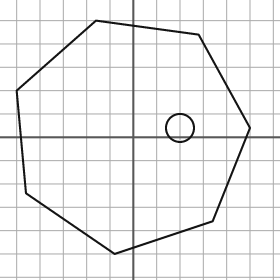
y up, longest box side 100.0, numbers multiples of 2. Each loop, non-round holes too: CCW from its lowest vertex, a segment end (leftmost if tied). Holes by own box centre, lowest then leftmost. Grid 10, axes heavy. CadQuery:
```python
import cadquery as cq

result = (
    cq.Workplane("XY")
    .moveTo(-8.0, -50.0)
    .lineTo(34.0, -36.0)
    .lineTo(50.0, 4.0)
    .lineTo(28.0, 44.0)
    .lineTo(-16.0, 50.0)
    .lineTo(-50.0, 20.0)
    .lineTo(-46.0, -24.0)
    .close()
    .moveTo(20.0, 4.0)
    .circle(6.0)
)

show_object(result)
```